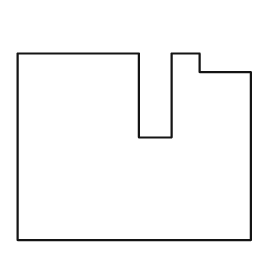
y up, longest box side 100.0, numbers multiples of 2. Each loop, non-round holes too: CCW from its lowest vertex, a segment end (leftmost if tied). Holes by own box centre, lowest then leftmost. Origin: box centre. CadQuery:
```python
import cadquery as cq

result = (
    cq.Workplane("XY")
    .moveTo(-50.0, -40.0)
    .lineTo(50.0, -40.0)
    .lineTo(50.0, 32.0)
    .lineTo(28.0, 32.0)
    .lineTo(28.0, 40.0)
    .lineTo(16.0, 40.0)
    .lineTo(16.0, 4.0)
    .lineTo(2.0, 4.0)
    .lineTo(2.0, 40.0)
    .lineTo(-50.0, 40.0)
    .close()
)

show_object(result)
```